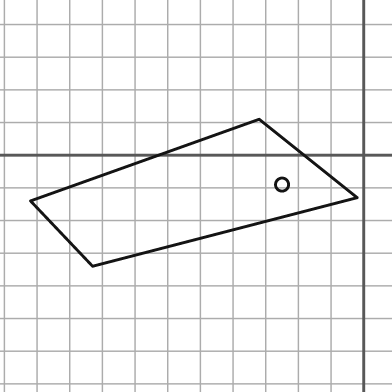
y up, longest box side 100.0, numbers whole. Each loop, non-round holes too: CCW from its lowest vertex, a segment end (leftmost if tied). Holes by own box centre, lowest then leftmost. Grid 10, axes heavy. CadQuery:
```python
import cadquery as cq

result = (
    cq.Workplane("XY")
    .moveTo(-83.0, -34.0)
    .lineTo(-2.0, -13.0)
    .lineTo(-32.0, 11.0)
    .lineTo(-102.0, -14.0)
    .close()
    .moveTo(-25.0, -9.0)
    .circle(2.0)
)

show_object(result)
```